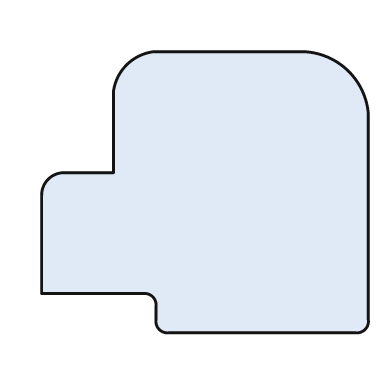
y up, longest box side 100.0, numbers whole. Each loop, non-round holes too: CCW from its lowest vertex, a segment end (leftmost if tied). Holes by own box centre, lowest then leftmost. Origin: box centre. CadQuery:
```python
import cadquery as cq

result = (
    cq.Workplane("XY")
    .moveTo(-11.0, -43.0)
    .lineTo(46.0, -43.0)
    .threePointArc((49.0, -42.0), (50.0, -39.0))
    .lineTo(50.0, 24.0)
    .threePointArc((44.0, 37.0), (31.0, 43.0))
    .lineTo(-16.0, 43.0)
    .threePointArc((-24.0, 39.0), (-28.0, 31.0))
    .lineTo(-28.0, 6.0)
    .lineTo(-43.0, 6.0)
    .threePointArc((-48.0, 4.0), (-50.0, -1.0))
    .lineTo(-50.0, -31.0)
    .lineTo(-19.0, -31.0)
    .threePointArc((-16.0, -32.0), (-15.0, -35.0))
    .lineTo(-15.0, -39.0)
    .threePointArc((-14.0, -42.0), (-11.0, -43.0))
    .close()
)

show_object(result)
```